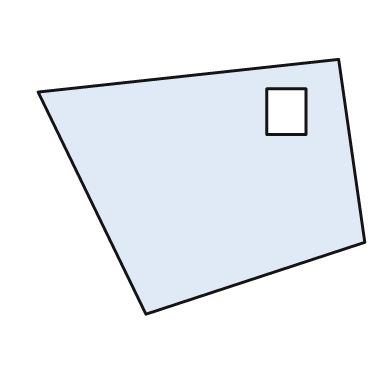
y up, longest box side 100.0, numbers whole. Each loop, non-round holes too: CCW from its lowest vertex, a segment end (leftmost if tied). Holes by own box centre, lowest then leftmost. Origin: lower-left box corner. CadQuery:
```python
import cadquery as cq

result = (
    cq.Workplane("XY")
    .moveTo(33.0, 0.0)
    .lineTo(100.0, 22.0)
    .lineTo(92.0, 78.0)
    .lineTo(0.0, 68.0)
    .close()
    .moveTo(70.0, 55.0)
    .lineTo(82.0, 55.0)
    .lineTo(82.0, 69.0)
    .lineTo(70.0, 69.0)
    .close()
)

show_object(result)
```